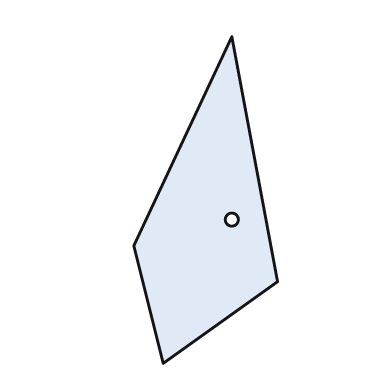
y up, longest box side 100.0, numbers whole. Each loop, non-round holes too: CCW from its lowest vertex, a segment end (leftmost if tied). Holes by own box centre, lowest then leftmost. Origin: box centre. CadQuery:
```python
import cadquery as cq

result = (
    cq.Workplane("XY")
    .moveTo(-13.0, -50.0)
    .lineTo(22.0, -25.0)
    .lineTo(8.0, 50.0)
    .lineTo(-22.0, -14.0)
    .close()
    .moveTo(8.0, -6.0)
    .circle(2.0)
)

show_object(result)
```